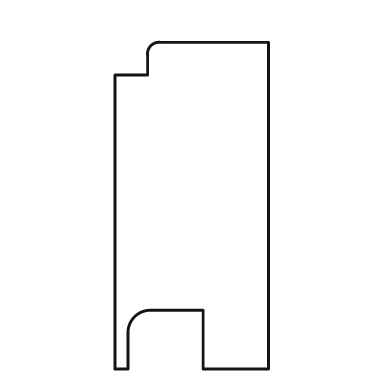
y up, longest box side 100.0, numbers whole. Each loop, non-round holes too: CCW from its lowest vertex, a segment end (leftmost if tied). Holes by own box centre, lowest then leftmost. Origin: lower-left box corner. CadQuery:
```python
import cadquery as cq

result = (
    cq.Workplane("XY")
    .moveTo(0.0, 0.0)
    .lineTo(4.0, 0.0)
    .lineTo(4.0, 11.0)
    .threePointArc((6.0, 16.0), (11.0, 18.0))
    .lineTo(27.0, 18.0)
    .lineTo(27.0, 0.0)
    .lineTo(47.0, 0.0)
    .lineTo(47.0, 100.0)
    .lineTo(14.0, 100.0)
    .threePointArc((11.0, 99.0), (10.0, 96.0))
    .lineTo(10.0, 90.0)
    .lineTo(0.0, 90.0)
    .close()
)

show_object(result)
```